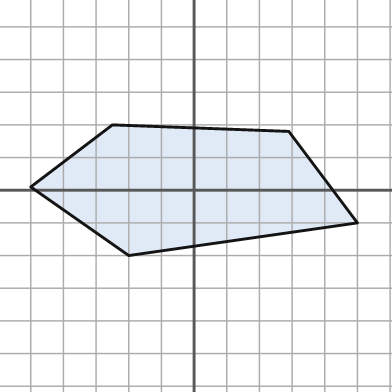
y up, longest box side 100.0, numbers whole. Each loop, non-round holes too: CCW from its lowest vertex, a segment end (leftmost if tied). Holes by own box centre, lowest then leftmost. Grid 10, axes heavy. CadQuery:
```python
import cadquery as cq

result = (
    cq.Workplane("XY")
    .moveTo(-20.0, -20.0)
    .lineTo(50.0, -10.0)
    .lineTo(29.0, 18.0)
    .lineTo(-25.0, 20.0)
    .lineTo(-50.0, 1.0)
    .close()
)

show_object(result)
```